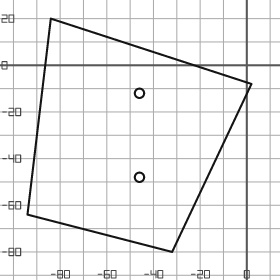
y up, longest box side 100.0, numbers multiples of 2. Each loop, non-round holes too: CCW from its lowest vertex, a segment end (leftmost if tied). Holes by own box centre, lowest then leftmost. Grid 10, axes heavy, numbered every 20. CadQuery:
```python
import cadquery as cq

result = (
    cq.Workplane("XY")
    .moveTo(-32.0, -80.0)
    .lineTo(2.0, -8.0)
    .lineTo(-84.0, 20.0)
    .lineTo(-94.0, -64.0)
    .close()
    .moveTo(-46.0, -48.0)
    .circle(2.0)
    .moveTo(-46.0, -12.0)
    .circle(2.0)
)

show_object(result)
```